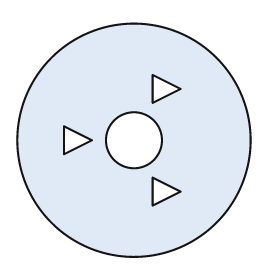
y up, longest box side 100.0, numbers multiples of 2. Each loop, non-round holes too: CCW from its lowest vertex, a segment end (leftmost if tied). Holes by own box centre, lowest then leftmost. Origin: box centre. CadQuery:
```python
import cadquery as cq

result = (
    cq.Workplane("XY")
    .moveTo(0.0, 0.0)
    .circle(50.0)
    .moveTo(8.0, -28.0)
    .lineTo(20.0, -22.0)
    .lineTo(8.0, -16.0)
    .close()
    .moveTo(-30.0, -6.0)
    .lineTo(-18.0, 0.0)
    .lineTo(-30.0, 6.0)
    .close()
    .moveTo(0.0, 0.0)
    .circle(12.0)
    .moveTo(8.0, 16.0)
    .lineTo(20.0, 22.0)
    .lineTo(8.0, 28.0)
    .close()
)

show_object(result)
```